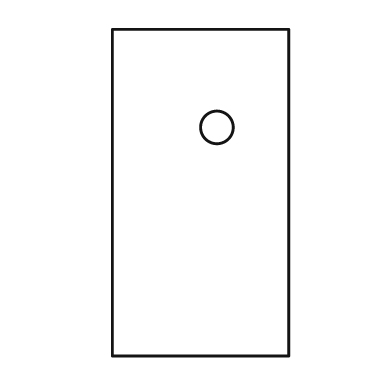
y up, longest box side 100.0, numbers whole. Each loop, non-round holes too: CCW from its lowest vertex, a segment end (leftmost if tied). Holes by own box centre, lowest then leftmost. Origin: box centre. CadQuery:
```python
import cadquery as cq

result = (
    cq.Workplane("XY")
    .moveTo(-27.0, -50.0)
    .lineTo(27.0, -50.0)
    .lineTo(27.0, 50.0)
    .lineTo(-27.0, 50.0)
    .close()
    .moveTo(5.0, 20.0)
    .circle(5.0)
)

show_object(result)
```